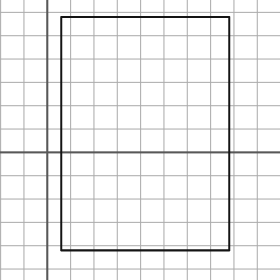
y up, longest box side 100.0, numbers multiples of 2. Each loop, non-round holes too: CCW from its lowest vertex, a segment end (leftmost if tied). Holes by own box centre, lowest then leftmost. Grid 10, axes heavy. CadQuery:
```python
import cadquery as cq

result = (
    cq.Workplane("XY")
    .moveTo(6.0, -42.0)
    .lineTo(78.0, -42.0)
    .lineTo(78.0, 58.0)
    .lineTo(6.0, 58.0)
    .close()
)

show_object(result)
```